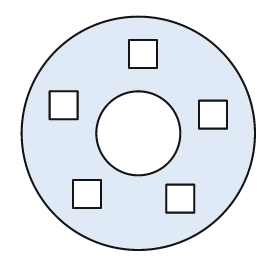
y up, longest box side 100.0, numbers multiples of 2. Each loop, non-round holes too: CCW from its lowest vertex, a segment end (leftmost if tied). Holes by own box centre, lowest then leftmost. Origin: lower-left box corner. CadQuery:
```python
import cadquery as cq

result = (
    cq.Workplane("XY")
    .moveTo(50.0, 50.0)
    .circle(50.0)
    .moveTo(62.0, 16.0)
    .lineTo(74.0, 16.0)
    .lineTo(74.0, 28.0)
    .lineTo(62.0, 28.0)
    .close()
    .moveTo(22.0, 18.0)
    .lineTo(34.0, 18.0)
    .lineTo(34.0, 30.0)
    .lineTo(22.0, 30.0)
    .close()
    .moveTo(50.0, 50.0)
    .circle(18.0)
    .moveTo(76.0, 52.0)
    .lineTo(88.0, 52.0)
    .lineTo(88.0, 64.0)
    .lineTo(76.0, 64.0)
    .close()
    .moveTo(12.0, 56.0)
    .lineTo(24.0, 56.0)
    .lineTo(24.0, 68.0)
    .lineTo(12.0, 68.0)
    .close()
    .moveTo(46.0, 78.0)
    .lineTo(58.0, 78.0)
    .lineTo(58.0, 90.0)
    .lineTo(46.0, 90.0)
    .close()
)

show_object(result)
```